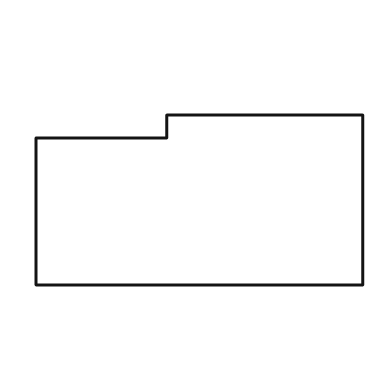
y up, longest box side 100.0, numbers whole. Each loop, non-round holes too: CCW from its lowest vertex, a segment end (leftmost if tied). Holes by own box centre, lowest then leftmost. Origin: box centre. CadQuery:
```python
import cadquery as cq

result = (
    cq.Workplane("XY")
    .moveTo(-50.0, -26.0)
    .lineTo(50.0, -26.0)
    .lineTo(50.0, 26.0)
    .lineTo(-10.0, 26.0)
    .lineTo(-10.0, 19.0)
    .lineTo(-50.0, 19.0)
    .close()
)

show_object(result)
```